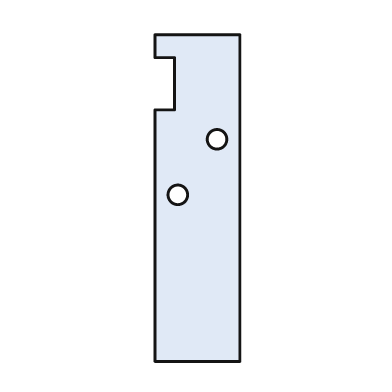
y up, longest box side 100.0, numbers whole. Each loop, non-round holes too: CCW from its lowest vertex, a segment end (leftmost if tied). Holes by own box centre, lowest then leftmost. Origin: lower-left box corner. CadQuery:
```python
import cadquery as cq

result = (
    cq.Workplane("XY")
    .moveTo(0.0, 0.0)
    .lineTo(26.0, 0.0)
    .lineTo(26.0, 100.0)
    .lineTo(0.0, 100.0)
    .lineTo(0.0, 93.0)
    .lineTo(6.0, 93.0)
    .lineTo(6.0, 77.0)
    .lineTo(0.0, 77.0)
    .close()
    .moveTo(7.0, 51.0)
    .circle(3.0)
    .moveTo(19.0, 68.0)
    .circle(3.0)
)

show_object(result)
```